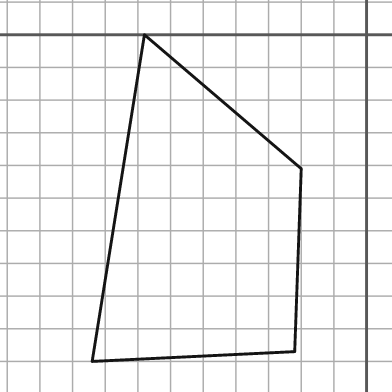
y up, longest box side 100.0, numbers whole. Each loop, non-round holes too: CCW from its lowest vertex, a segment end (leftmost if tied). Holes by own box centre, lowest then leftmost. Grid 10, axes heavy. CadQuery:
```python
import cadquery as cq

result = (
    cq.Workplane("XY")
    .moveTo(-84.0, -100.0)
    .lineTo(-22.0, -97.0)
    .lineTo(-20.0, -41.0)
    .lineTo(-68.0, 0.0)
    .close()
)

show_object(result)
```